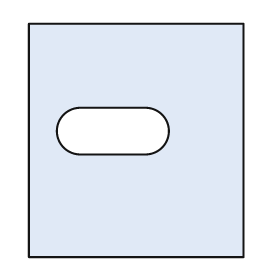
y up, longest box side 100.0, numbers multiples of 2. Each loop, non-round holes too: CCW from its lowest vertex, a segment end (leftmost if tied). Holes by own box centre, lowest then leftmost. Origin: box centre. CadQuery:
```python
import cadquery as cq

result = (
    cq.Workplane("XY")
    .moveTo(-46.0, -50.0)
    .lineTo(46.0, -50.0)
    .lineTo(46.0, 50.0)
    .lineTo(-46.0, 50.0)
    .close()
    .moveTo(-24.0, -6.0)
    .lineTo(4.0, -6.0)
    .threePointArc((14.0, 4.0), (4.0, 14.0))
    .lineTo(-24.0, 14.0)
    .threePointArc((-34.0, 4.0), (-24.0, -6.0))
    .close()
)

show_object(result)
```